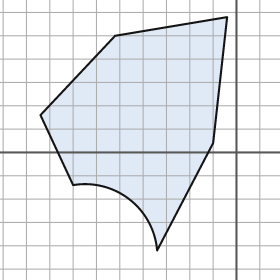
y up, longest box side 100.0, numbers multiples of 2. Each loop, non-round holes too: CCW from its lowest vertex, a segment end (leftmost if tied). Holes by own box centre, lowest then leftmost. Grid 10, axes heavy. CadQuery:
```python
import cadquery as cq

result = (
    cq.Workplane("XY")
    .moveTo(-34.0, -42.0)
    .lineTo(-10.0, 4.0)
    .lineTo(-4.0, 58.0)
    .lineTo(-52.0, 50.0)
    .lineTo(-84.0, 16.0)
    .lineTo(-70.0, -14.0)
    .threePointArc((-46.0, -20.0), (-34.0, -42.0))
    .close()
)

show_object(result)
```